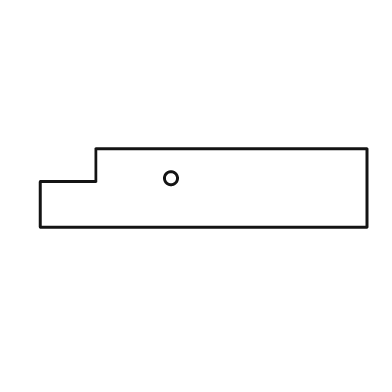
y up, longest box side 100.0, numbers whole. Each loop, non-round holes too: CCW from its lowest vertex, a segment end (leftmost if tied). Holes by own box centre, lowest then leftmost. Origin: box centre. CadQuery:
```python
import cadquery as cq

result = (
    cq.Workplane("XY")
    .moveTo(-50.0, -12.0)
    .lineTo(50.0, -12.0)
    .lineTo(50.0, 12.0)
    .lineTo(-33.0, 12.0)
    .lineTo(-33.0, 2.0)
    .lineTo(-50.0, 2.0)
    .close()
    .moveTo(-10.0, 3.0)
    .circle(2.0)
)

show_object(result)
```